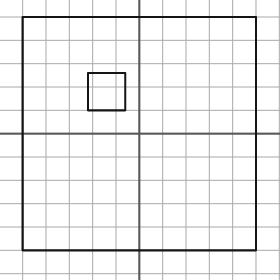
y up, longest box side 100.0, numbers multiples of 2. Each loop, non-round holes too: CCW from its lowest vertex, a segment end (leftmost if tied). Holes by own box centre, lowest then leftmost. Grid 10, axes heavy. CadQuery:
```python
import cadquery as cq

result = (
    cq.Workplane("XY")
    .moveTo(-50.0, -50.0)
    .lineTo(50.0, -50.0)
    .lineTo(50.0, 50.0)
    .lineTo(-50.0, 50.0)
    .close()
    .moveTo(-22.0, 10.0)
    .lineTo(-6.0, 10.0)
    .lineTo(-6.0, 26.0)
    .lineTo(-22.0, 26.0)
    .close()
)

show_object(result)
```